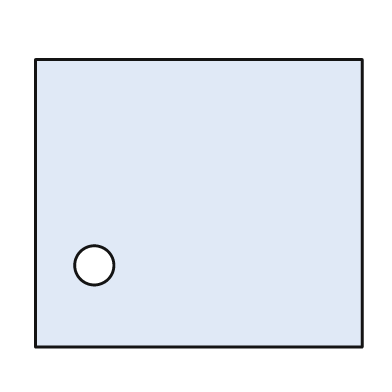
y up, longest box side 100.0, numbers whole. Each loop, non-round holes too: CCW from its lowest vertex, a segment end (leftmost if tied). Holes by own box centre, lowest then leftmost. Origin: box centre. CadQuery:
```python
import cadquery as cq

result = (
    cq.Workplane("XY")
    .moveTo(-50.0, -44.0)
    .lineTo(50.0, -44.0)
    .lineTo(50.0, 44.0)
    .lineTo(-50.0, 44.0)
    .close()
    .moveTo(-32.0, -19.0)
    .circle(6.0)
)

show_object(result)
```